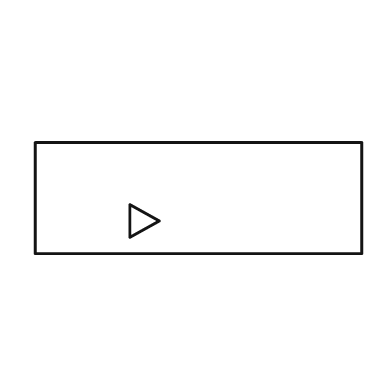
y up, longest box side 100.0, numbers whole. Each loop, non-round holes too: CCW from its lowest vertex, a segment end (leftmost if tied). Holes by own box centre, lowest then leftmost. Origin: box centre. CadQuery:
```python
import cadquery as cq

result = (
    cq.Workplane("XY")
    .moveTo(-50.0, -17.0)
    .lineTo(50.0, -17.0)
    .lineTo(50.0, 17.0)
    .lineTo(-50.0, 17.0)
    .close()
    .moveTo(-21.0, -12.0)
    .lineTo(-12.0, -7.0)
    .lineTo(-21.0, -2.0)
    .close()
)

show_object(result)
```